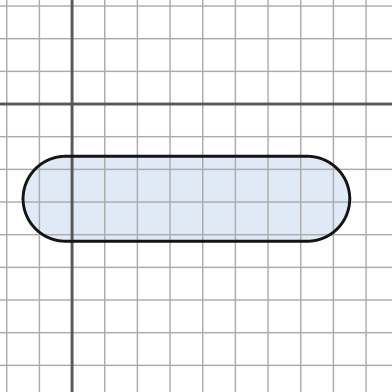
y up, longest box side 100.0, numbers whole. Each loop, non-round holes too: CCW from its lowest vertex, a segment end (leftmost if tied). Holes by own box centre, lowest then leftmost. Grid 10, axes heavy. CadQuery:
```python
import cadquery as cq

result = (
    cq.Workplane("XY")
    .moveTo(-2.0, -42.0)
    .lineTo(72.0, -42.0)
    .threePointArc((85.0, -29.0), (72.0, -16.0))
    .lineTo(-2.0, -16.0)
    .threePointArc((-15.0, -29.0), (-2.0, -42.0))
    .close()
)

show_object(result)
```